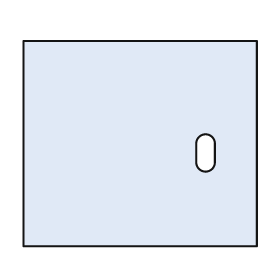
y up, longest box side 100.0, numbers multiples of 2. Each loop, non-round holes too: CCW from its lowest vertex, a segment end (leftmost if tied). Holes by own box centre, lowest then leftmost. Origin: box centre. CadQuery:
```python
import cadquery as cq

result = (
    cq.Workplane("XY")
    .moveTo(-50.0, -44.0)
    .lineTo(50.0, -44.0)
    .lineTo(50.0, 44.0)
    .lineTo(-50.0, 44.0)
    .close()
    .moveTo(24.0, -8.0)
    .threePointArc((28.0, -12.0), (32.0, -8.0))
    .lineTo(32.0, 0.0)
    .threePointArc((28.0, 4.0), (24.0, 0.0))
    .close()
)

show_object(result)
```